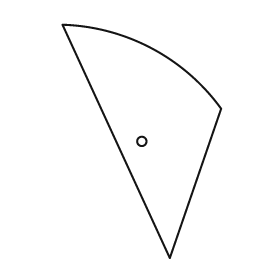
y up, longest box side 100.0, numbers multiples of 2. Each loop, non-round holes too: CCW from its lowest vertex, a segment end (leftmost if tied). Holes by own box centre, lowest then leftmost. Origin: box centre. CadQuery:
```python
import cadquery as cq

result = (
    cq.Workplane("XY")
    .moveTo(12.0, -50.0)
    .lineTo(34.0, 14.0)
    .threePointArc((4.0, 40.0), (-34.0, 50.0))
    .close()
    .moveTo(0.0, 0.0)
    .circle(2.0)
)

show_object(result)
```